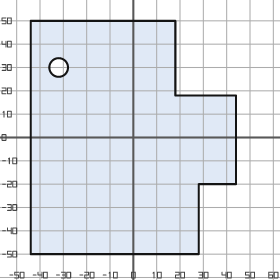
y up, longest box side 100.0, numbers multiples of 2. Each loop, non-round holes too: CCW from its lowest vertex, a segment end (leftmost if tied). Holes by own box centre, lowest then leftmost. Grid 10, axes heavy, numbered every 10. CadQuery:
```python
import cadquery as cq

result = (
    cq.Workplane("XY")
    .moveTo(-44.0, -50.0)
    .lineTo(28.0, -50.0)
    .lineTo(28.0, -20.0)
    .lineTo(44.0, -20.0)
    .lineTo(44.0, 18.0)
    .lineTo(18.0, 18.0)
    .lineTo(18.0, 50.0)
    .lineTo(-44.0, 50.0)
    .close()
    .moveTo(-32.0, 30.0)
    .circle(4.0)
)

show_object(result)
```